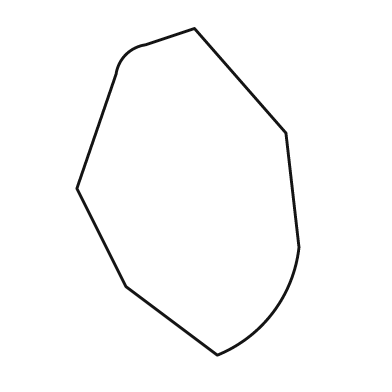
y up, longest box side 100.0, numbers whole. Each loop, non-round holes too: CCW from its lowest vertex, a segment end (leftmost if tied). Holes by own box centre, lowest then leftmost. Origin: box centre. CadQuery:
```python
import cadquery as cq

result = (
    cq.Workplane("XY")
    .moveTo(9.0, -50.0)
    .threePointArc((26.0, -37.0), (34.0, -17.0))
    .lineTo(30.0, 18.0)
    .lineTo(2.0, 50.0)
    .lineTo(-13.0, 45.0)
    .threePointArc((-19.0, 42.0), (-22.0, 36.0))
    .lineTo(-34.0, 1.0)
    .lineTo(-19.0, -29.0)
    .close()
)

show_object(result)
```